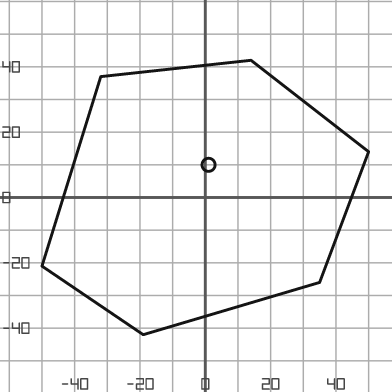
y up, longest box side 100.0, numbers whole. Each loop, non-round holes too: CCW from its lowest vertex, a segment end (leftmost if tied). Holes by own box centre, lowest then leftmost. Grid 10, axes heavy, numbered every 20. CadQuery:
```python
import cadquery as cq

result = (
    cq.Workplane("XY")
    .moveTo(-19.0, -42.0)
    .lineTo(35.0, -26.0)
    .lineTo(50.0, 14.0)
    .lineTo(14.0, 42.0)
    .lineTo(-32.0, 37.0)
    .lineTo(-50.0, -21.0)
    .close()
    .moveTo(1.0, 10.0)
    .circle(2.0)
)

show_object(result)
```